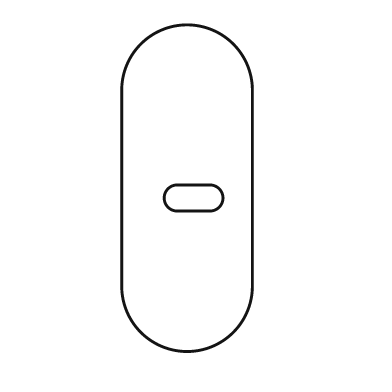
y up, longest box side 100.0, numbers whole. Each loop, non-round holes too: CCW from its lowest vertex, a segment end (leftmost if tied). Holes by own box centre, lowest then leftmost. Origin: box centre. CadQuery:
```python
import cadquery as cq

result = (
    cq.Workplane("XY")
    .moveTo(-20.0, -30.0)
    .threePointArc((0.0, -50.0), (20.0, -30.0))
    .lineTo(20.0, 30.0)
    .threePointArc((0.0, 50.0), (-20.0, 30.0))
    .close()
    .moveTo(-3.0, -7.0)
    .lineTo(7.0, -7.0)
    .threePointArc((11.0, -3.0), (7.0, 1.0))
    .lineTo(-3.0, 1.0)
    .threePointArc((-7.0, -3.0), (-3.0, -7.0))
    .close()
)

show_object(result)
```